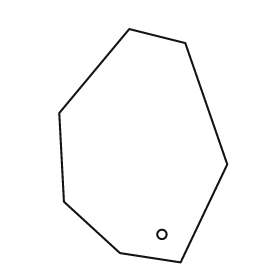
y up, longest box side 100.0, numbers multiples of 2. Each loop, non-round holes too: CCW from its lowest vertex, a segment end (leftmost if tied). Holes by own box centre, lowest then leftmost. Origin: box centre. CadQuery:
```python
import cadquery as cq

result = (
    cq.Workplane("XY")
    .moveTo(16.0, -50.0)
    .lineTo(36.0, -8.0)
    .lineTo(18.0, 44.0)
    .lineTo(-6.0, 50.0)
    .lineTo(-36.0, 14.0)
    .lineTo(-34.0, -24.0)
    .lineTo(-10.0, -46.0)
    .close()
    .moveTo(8.0, -38.0)
    .circle(2.0)
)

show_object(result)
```